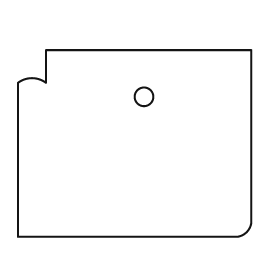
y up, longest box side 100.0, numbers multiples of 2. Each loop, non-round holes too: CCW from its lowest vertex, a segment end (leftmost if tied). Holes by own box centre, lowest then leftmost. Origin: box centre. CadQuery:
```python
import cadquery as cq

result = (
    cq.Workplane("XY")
    .moveTo(-50.0, -40.0)
    .lineTo(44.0, -40.0)
    .threePointArc((48.0, -38.0), (50.0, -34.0))
    .lineTo(50.0, 40.0)
    .lineTo(-38.0, 40.0)
    .lineTo(-38.0, 26.0)
    .threePointArc((-44.0, 28.0), (-50.0, 26.0))
    .close()
    .moveTo(4.0, 20.0)
    .circle(4.0)
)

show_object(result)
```